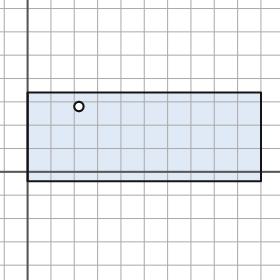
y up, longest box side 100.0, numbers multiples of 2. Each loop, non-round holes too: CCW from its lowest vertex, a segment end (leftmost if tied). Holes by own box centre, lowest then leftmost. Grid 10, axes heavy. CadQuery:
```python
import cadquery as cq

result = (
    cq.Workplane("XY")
    .moveTo(0.0, -4.0)
    .lineTo(100.0, -4.0)
    .lineTo(100.0, 34.0)
    .lineTo(0.0, 34.0)
    .close()
    .moveTo(22.0, 28.0)
    .circle(2.0)
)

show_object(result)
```